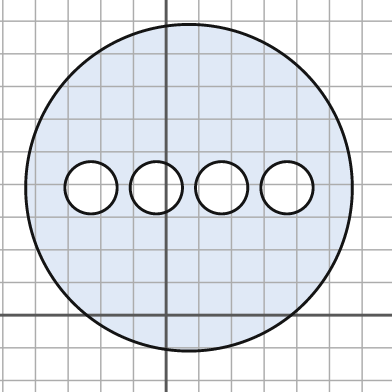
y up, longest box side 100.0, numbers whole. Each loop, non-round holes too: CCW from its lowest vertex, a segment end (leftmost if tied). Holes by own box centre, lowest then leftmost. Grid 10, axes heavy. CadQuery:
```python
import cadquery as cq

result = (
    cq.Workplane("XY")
    .moveTo(7.0, 39.0)
    .circle(50.0)
    .moveTo(-23.0, 39.0)
    .circle(8.0)
    .moveTo(-3.0, 39.0)
    .circle(8.0)
    .moveTo(17.0, 39.0)
    .circle(8.0)
    .moveTo(37.0, 39.0)
    .circle(8.0)
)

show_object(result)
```